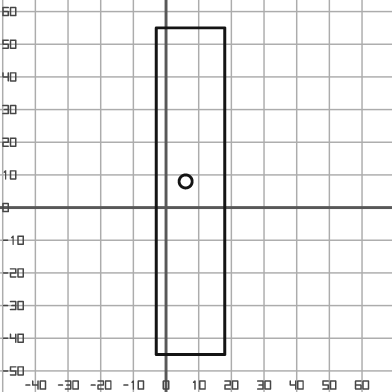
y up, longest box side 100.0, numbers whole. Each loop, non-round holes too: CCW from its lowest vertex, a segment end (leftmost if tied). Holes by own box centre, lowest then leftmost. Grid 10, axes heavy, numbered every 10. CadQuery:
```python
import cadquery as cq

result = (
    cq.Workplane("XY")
    .moveTo(-3.0, -45.0)
    .lineTo(18.0, -45.0)
    .lineTo(18.0, 55.0)
    .lineTo(-3.0, 55.0)
    .close()
    .moveTo(6.0, 8.0)
    .circle(2.0)
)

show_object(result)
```